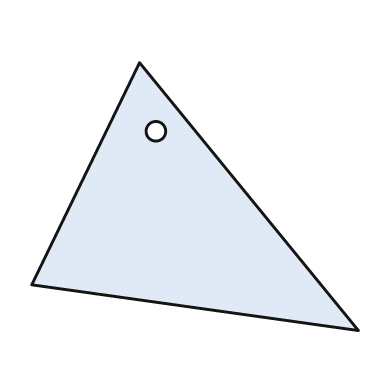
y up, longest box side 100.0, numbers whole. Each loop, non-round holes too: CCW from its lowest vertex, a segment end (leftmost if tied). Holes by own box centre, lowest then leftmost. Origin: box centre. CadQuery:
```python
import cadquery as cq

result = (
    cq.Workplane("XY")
    .moveTo(50.0, -41.0)
    .lineTo(-17.0, 41.0)
    .lineTo(-50.0, -27.0)
    .close()
    .moveTo(-12.0, 20.0)
    .circle(3.0)
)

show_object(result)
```